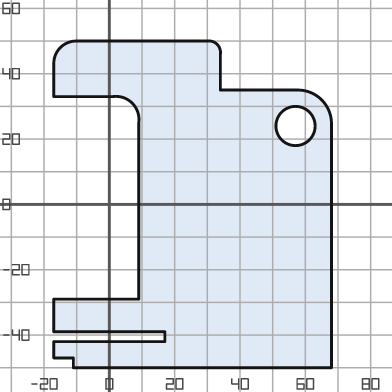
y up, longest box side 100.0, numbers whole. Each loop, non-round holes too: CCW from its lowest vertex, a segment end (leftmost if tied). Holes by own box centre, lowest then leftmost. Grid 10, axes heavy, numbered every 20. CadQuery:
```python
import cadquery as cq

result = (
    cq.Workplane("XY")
    .moveTo(-11.0, -50.0)
    .lineTo(68.0, -50.0)
    .lineTo(68.0, 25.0)
    .threePointArc((65.0, 32.0), (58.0, 35.0))
    .lineTo(34.0, 35.0)
    .lineTo(34.0, 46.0)
    .threePointArc((33.0, 49.0), (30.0, 50.0))
    .lineTo(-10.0, 50.0)
    .threePointArc((-15.0, 48.0), (-17.0, 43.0))
    .lineTo(-17.0, 33.0)
    .lineTo(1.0, 33.0)
    .threePointArc((7.0, 31.0), (9.0, 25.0))
    .lineTo(9.0, -29.0)
    .lineTo(-17.0, -29.0)
    .lineTo(-17.0, -39.0)
    .lineTo(17.0, -39.0)
    .lineTo(17.0, -42.0)
    .lineTo(-17.0, -42.0)
    .lineTo(-17.0, -47.0)
    .lineTo(-11.0, -47.0)
    .close()
    .moveTo(57.0, 24.0)
    .circle(6.0)
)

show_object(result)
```